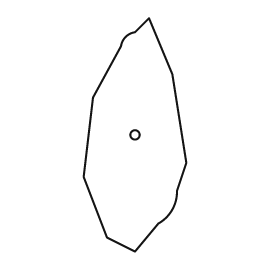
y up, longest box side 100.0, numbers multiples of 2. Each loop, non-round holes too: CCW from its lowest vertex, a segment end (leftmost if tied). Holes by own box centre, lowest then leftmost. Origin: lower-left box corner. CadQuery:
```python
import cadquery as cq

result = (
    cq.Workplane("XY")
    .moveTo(22.0, 0.0)
    .lineTo(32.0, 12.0)
    .threePointArc((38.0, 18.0), (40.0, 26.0))
    .lineTo(44.0, 38.0)
    .lineTo(38.0, 76.0)
    .lineTo(28.0, 100.0)
    .lineTo(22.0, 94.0)
    .threePointArc((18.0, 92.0), (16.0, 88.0))
    .lineTo(4.0, 66.0)
    .lineTo(0.0, 32.0)
    .lineTo(10.0, 6.0)
    .close()
    .moveTo(22.0, 50.0)
    .circle(2.0)
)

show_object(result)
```